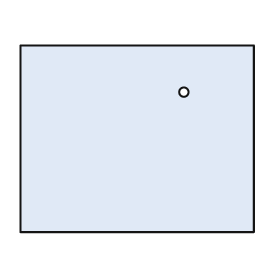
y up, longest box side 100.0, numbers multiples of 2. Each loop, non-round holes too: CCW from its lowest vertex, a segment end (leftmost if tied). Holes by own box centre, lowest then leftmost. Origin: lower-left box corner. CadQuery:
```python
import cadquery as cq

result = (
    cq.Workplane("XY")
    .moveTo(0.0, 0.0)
    .lineTo(100.0, 0.0)
    .lineTo(100.0, 80.0)
    .lineTo(0.0, 80.0)
    .close()
    .moveTo(70.0, 60.0)
    .circle(2.0)
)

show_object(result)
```